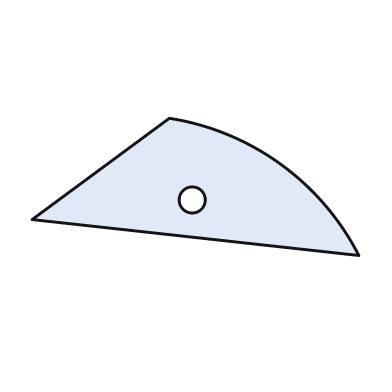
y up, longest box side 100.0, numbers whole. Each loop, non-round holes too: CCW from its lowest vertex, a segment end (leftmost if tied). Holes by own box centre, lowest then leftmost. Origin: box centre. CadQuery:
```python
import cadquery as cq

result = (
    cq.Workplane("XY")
    .moveTo(50.0, -21.0)
    .threePointArc((26.0, 7.0), (-8.0, 21.0))
    .lineTo(-50.0, -10.0)
    .close()
    .moveTo(-1.0, -4.0)
    .circle(4.0)
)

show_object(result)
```